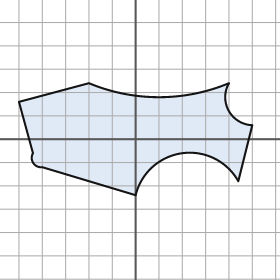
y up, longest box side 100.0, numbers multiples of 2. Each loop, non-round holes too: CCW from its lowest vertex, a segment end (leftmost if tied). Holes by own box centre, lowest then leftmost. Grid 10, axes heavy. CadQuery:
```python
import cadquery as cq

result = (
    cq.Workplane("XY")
    .moveTo(0.0, -24.0)
    .threePointArc((20.0, -6.0), (44.0, -18.0))
    .lineTo(50.0, 6.0)
    .threePointArc((40.0, 12.0), (40.0, 24.0))
    .threePointArc((10.0, 18.0), (-20.0, 24.0))
    .lineTo(-50.0, 16.0)
    .lineTo(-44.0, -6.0)
    .threePointArc((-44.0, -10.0), (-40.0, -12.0))
    .close()
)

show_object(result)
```